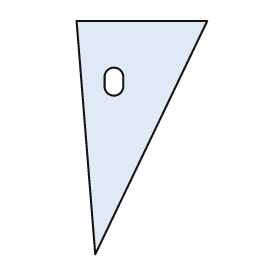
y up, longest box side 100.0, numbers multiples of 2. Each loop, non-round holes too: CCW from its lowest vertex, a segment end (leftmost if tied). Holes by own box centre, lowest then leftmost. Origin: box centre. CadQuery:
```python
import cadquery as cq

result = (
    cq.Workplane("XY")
    .moveTo(-20.0, -50.0)
    .lineTo(28.0, 50.0)
    .lineTo(-28.0, 50.0)
    .close()
    .moveTo(-16.0, 22.0)
    .threePointArc((-12.0, 18.0), (-8.0, 22.0))
    .lineTo(-8.0, 26.0)
    .threePointArc((-12.0, 30.0), (-16.0, 26.0))
    .close()
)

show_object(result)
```